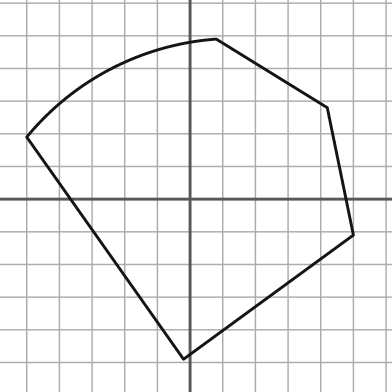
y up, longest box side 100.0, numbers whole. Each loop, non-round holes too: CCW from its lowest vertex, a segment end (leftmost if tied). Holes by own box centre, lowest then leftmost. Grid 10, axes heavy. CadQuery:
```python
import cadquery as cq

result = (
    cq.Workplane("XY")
    .moveTo(-2.0, -49.0)
    .lineTo(50.0, -11.0)
    .lineTo(42.0, 28.0)
    .lineTo(8.0, 49.0)
    .threePointArc((-24.0, 40.0), (-50.0, 19.0))
    .close()
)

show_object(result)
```